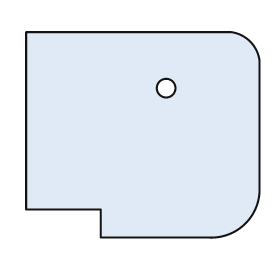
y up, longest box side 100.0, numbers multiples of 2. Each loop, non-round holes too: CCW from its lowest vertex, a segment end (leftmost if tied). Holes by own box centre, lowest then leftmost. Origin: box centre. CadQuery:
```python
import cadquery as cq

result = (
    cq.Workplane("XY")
    .moveTo(-18.0, -44.0)
    .lineTo(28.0, -44.0)
    .threePointArc((44.0, -38.0), (50.0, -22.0))
    .lineTo(50.0, 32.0)
    .threePointArc((46.0, 40.0), (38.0, 44.0))
    .lineTo(-50.0, 44.0)
    .lineTo(-50.0, -32.0)
    .lineTo(-18.0, -32.0)
    .close()
    .moveTo(10.0, 20.0)
    .circle(4.0)
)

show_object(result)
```